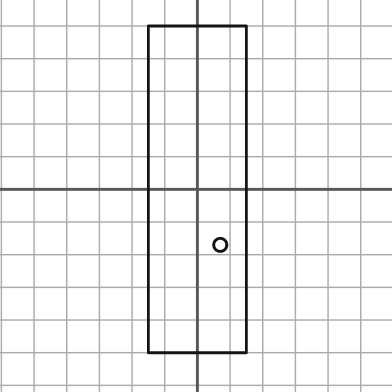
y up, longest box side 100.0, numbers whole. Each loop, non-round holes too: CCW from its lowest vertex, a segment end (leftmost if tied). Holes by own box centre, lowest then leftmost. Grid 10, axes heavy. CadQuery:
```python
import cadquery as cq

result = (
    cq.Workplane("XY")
    .moveTo(-15.0, -50.0)
    .lineTo(15.0, -50.0)
    .lineTo(15.0, 50.0)
    .lineTo(-15.0, 50.0)
    .close()
    .moveTo(7.0, -17.0)
    .circle(2.0)
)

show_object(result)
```